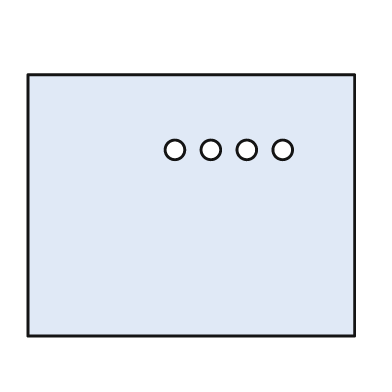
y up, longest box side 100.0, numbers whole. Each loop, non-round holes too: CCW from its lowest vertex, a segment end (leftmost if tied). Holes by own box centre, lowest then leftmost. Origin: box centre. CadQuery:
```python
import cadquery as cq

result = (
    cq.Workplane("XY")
    .moveTo(-50.0, -40.0)
    .lineTo(50.0, -40.0)
    .lineTo(50.0, 40.0)
    .lineTo(-50.0, 40.0)
    .close()
    .moveTo(-5.0, 17.0)
    .circle(3.0)
    .moveTo(6.0, 17.0)
    .circle(3.0)
    .moveTo(17.0, 17.0)
    .circle(3.0)
    .moveTo(28.0, 17.0)
    .circle(3.0)
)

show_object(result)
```